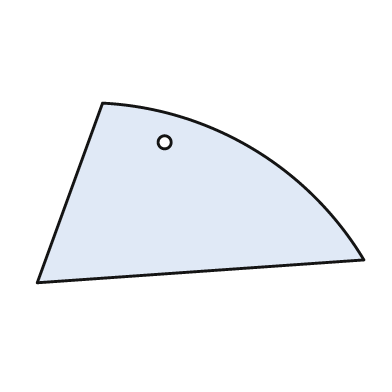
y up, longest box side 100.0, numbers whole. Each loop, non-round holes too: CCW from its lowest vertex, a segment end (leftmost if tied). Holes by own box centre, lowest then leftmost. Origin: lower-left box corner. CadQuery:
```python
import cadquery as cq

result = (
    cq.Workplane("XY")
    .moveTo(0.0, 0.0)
    .lineTo(100.0, 7.0)
    .threePointArc((66.0, 41.0), (20.0, 55.0))
    .close()
    .moveTo(39.0, 43.0)
    .circle(2.0)
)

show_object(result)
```